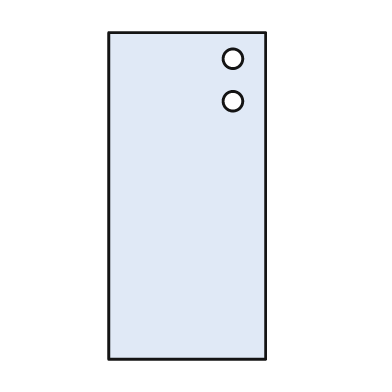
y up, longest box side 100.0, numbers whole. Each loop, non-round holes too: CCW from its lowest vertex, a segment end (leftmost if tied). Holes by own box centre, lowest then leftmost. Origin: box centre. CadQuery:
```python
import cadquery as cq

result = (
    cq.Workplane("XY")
    .moveTo(-24.0, -50.0)
    .lineTo(24.0, -50.0)
    .lineTo(24.0, 50.0)
    .lineTo(-24.0, 50.0)
    .close()
    .moveTo(14.0, 29.0)
    .circle(3.0)
    .moveTo(14.0, 42.0)
    .circle(3.0)
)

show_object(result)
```